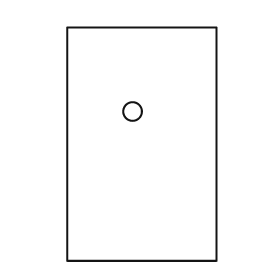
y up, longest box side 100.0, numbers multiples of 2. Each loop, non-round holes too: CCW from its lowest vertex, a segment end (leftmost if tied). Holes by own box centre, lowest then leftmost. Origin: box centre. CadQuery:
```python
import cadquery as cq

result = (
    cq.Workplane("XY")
    .moveTo(-32.0, -50.0)
    .lineTo(32.0, -50.0)
    .lineTo(32.0, 50.0)
    .lineTo(-32.0, 50.0)
    .close()
    .moveTo(-4.0, 14.0)
    .circle(4.0)
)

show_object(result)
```